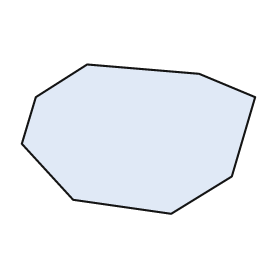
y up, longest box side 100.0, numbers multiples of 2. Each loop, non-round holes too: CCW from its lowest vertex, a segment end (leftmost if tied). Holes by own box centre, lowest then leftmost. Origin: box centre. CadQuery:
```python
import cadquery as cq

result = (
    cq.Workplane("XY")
    .moveTo(14.0, -32.0)
    .lineTo(40.0, -16.0)
    .lineTo(50.0, 18.0)
    .lineTo(26.0, 28.0)
    .lineTo(-22.0, 32.0)
    .lineTo(-44.0, 18.0)
    .lineTo(-50.0, -2.0)
    .lineTo(-28.0, -26.0)
    .close()
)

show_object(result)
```